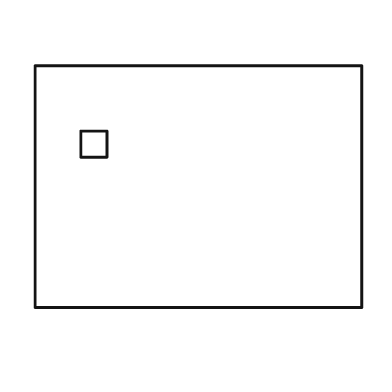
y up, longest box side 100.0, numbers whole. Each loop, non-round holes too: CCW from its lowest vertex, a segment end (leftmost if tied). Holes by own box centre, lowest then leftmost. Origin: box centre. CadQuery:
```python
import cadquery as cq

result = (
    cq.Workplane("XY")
    .moveTo(-50.0, -37.0)
    .lineTo(50.0, -37.0)
    .lineTo(50.0, 37.0)
    .lineTo(-50.0, 37.0)
    .close()
    .moveTo(-36.0, 9.0)
    .lineTo(-28.0, 9.0)
    .lineTo(-28.0, 17.0)
    .lineTo(-36.0, 17.0)
    .close()
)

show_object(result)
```